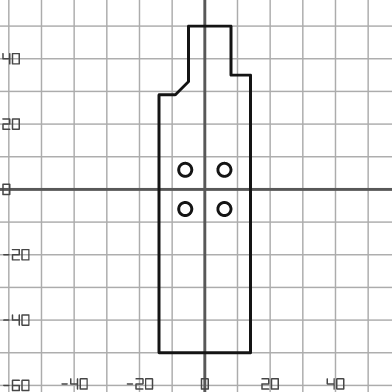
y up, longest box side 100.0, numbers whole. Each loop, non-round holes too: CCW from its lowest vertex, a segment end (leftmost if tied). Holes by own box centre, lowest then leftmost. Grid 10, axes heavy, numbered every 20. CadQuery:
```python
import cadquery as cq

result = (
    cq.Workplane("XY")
    .moveTo(-14.0, -50.0)
    .lineTo(14.0, -50.0)
    .lineTo(14.0, 35.0)
    .lineTo(8.0, 35.0)
    .lineTo(8.0, 50.0)
    .lineTo(-5.0, 50.0)
    .lineTo(-5.0, 33.0)
    .lineTo(-9.0, 29.0)
    .lineTo(-14.0, 29.0)
    .close()
    .moveTo(-6.0, -6.0)
    .circle(2.0)
    .moveTo(6.0, -6.0)
    .circle(2.0)
    .moveTo(-6.0, 6.0)
    .circle(2.0)
    .moveTo(6.0, 6.0)
    .circle(2.0)
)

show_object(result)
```